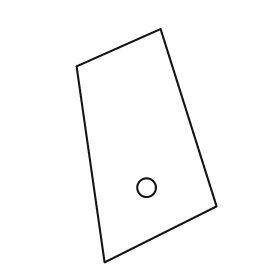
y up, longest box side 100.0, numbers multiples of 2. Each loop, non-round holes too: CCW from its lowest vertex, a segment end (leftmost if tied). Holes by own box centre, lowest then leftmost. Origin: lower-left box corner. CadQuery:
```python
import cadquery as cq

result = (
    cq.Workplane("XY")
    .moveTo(12.0, 0.0)
    .lineTo(60.0, 24.0)
    .lineTo(36.0, 100.0)
    .lineTo(0.0, 84.0)
    .close()
    .moveTo(30.0, 32.0)
    .circle(4.0)
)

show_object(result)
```